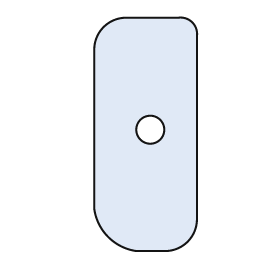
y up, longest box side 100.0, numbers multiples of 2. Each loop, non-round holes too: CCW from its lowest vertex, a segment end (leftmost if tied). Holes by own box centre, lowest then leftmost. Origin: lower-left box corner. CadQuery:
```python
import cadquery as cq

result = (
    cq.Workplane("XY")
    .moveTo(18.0, 0.0)
    .lineTo(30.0, 0.0)
    .threePointArc((40.0, 4.0), (44.0, 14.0))
    .lineTo(44.0, 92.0)
    .threePointArc((42.0, 98.0), (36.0, 100.0))
    .lineTo(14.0, 100.0)
    .threePointArc((4.0, 96.0), (0.0, 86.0))
    .lineTo(0.0, 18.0)
    .threePointArc((6.0, 6.0), (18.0, 0.0))
    .close()
    .moveTo(24.0, 52.0)
    .circle(6.0)
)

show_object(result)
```